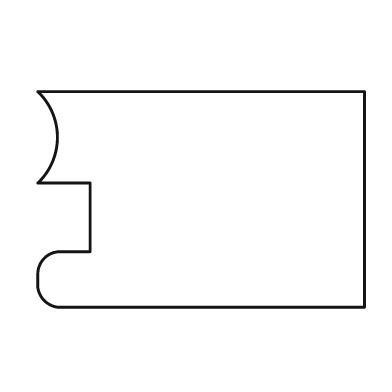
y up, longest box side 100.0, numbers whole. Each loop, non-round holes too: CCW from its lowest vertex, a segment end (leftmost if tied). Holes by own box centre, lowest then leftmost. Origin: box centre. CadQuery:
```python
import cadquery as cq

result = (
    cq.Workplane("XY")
    .moveTo(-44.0, -33.0)
    .lineTo(50.0, -33.0)
    .lineTo(50.0, 33.0)
    .lineTo(-50.0, 33.0)
    .threePointArc((-44.0, 19.0), (-50.0, 5.0))
    .lineTo(-34.0, 5.0)
    .lineTo(-34.0, -16.0)
    .lineTo(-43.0, -16.0)
    .threePointArc((-48.0, -18.0), (-50.0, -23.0))
    .lineTo(-50.0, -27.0)
    .threePointArc((-48.0, -31.0), (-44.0, -33.0))
    .close()
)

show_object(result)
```